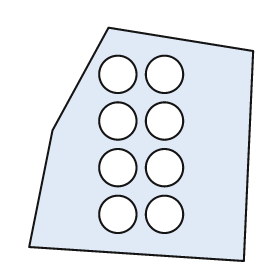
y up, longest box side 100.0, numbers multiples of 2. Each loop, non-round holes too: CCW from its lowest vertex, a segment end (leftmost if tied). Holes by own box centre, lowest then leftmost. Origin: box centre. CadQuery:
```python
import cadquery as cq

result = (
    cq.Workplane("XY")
    .moveTo(44.0, -50.0)
    .lineTo(48.0, 40.0)
    .lineTo(-14.0, 50.0)
    .lineTo(-38.0, 6.0)
    .lineTo(-48.0, -44.0)
    .close()
    .moveTo(-10.0, -30.0)
    .circle(8.0)
    .moveTo(10.0, -30.0)
    .circle(8.0)
    .moveTo(-10.0, -10.0)
    .circle(8.0)
    .moveTo(10.0, -10.0)
    .circle(8.0)
    .moveTo(-10.0, 10.0)
    .circle(8.0)
    .moveTo(10.0, 10.0)
    .circle(8.0)
    .moveTo(-10.0, 30.0)
    .circle(8.0)
    .moveTo(10.0, 30.0)
    .circle(8.0)
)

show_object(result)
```